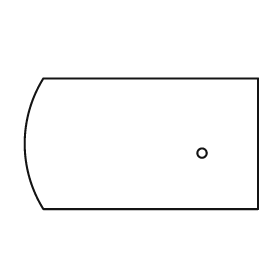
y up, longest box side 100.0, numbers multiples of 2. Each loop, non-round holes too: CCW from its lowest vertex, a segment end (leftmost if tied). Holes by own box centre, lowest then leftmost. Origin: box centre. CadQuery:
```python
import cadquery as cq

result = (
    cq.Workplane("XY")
    .moveTo(-42.0, -28.0)
    .lineTo(50.0, -28.0)
    .lineTo(50.0, 28.0)
    .lineTo(-42.0, 28.0)
    .threePointArc((-50.0, 0.0), (-42.0, -28.0))
    .close()
    .moveTo(26.0, -4.0)
    .circle(2.0)
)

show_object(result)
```